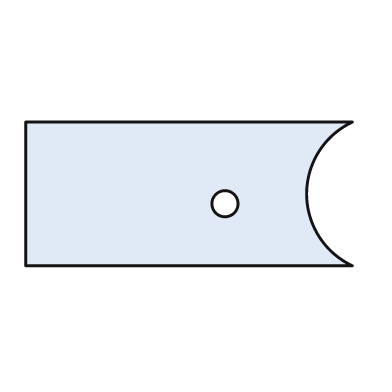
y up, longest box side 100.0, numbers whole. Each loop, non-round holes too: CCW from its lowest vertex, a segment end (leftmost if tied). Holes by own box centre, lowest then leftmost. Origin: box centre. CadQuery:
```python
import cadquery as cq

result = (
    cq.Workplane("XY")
    .moveTo(-50.0, -22.0)
    .lineTo(50.0, -22.0)
    .threePointArc((36.0, 0.0), (50.0, 22.0))
    .lineTo(-50.0, 22.0)
    .close()
    .moveTo(11.0, -3.0)
    .circle(4.0)
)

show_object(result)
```